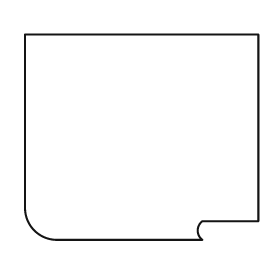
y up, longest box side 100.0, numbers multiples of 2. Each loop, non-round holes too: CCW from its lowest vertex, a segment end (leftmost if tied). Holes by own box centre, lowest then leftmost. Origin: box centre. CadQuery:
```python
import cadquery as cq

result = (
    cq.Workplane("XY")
    .moveTo(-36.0, -44.0)
    .lineTo(26.0, -44.0)
    .threePointArc((24.0, -40.0), (26.0, -36.0))
    .lineTo(50.0, -36.0)
    .lineTo(50.0, 44.0)
    .lineTo(-50.0, 44.0)
    .lineTo(-50.0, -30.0)
    .threePointArc((-46.0, -40.0), (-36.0, -44.0))
    .close()
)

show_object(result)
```